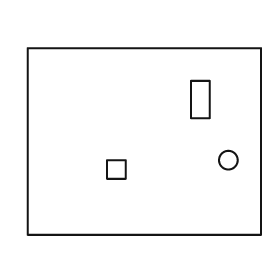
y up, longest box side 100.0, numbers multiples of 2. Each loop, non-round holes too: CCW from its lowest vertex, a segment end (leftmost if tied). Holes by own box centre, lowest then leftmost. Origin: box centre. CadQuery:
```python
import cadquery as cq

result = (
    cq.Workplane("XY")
    .moveTo(-50.0, -40.0)
    .lineTo(50.0, -40.0)
    .lineTo(50.0, 40.0)
    .lineTo(-50.0, 40.0)
    .close()
    .moveTo(-16.0, -16.0)
    .lineTo(-8.0, -16.0)
    .lineTo(-8.0, -8.0)
    .lineTo(-16.0, -8.0)
    .close()
    .moveTo(36.0, -8.0)
    .circle(4.0)
    .moveTo(20.0, 10.0)
    .lineTo(28.0, 10.0)
    .lineTo(28.0, 26.0)
    .lineTo(20.0, 26.0)
    .close()
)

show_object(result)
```